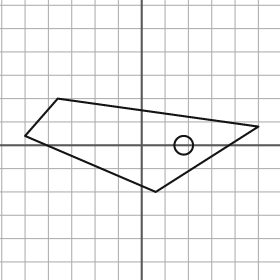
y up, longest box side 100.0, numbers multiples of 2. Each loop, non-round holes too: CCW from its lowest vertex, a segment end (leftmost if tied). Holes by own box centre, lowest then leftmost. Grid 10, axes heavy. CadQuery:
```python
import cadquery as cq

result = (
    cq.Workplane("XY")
    .moveTo(6.0, -20.0)
    .lineTo(50.0, 8.0)
    .lineTo(-36.0, 20.0)
    .lineTo(-50.0, 4.0)
    .close()
    .moveTo(18.0, 0.0)
    .circle(4.0)
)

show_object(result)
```